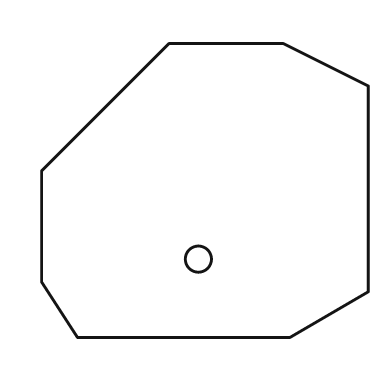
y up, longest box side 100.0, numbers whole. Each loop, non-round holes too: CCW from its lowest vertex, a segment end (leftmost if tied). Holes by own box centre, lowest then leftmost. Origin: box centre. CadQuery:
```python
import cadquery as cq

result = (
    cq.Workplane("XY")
    .moveTo(-39.0, -45.0)
    .lineTo(26.0, -45.0)
    .lineTo(50.0, -31.0)
    .lineTo(50.0, 32.0)
    .lineTo(24.0, 45.0)
    .lineTo(-11.0, 45.0)
    .lineTo(-50.0, 6.0)
    .lineTo(-50.0, -28.0)
    .close()
    .moveTo(-2.0, -21.0)
    .circle(4.0)
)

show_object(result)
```